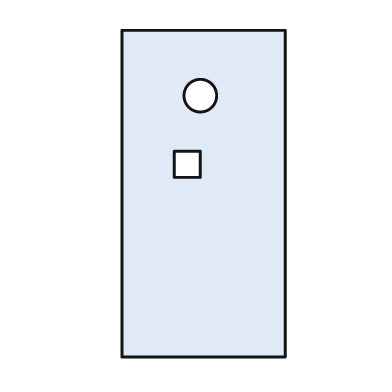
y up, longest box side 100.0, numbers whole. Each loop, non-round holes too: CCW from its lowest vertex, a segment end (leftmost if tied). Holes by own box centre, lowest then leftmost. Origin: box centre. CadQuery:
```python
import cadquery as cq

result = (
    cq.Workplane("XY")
    .moveTo(-25.0, -50.0)
    .lineTo(25.0, -50.0)
    .lineTo(25.0, 50.0)
    .lineTo(-25.0, 50.0)
    .close()
    .moveTo(-9.0, 5.0)
    .lineTo(-1.0, 5.0)
    .lineTo(-1.0, 13.0)
    .lineTo(-9.0, 13.0)
    .close()
    .moveTo(-1.0, 30.0)
    .circle(5.0)
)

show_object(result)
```